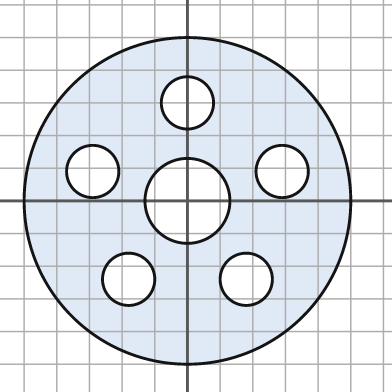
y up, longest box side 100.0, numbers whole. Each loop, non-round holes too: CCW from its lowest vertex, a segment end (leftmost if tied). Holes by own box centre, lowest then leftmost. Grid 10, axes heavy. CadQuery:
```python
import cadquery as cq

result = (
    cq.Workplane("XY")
    .moveTo(0.0, 0.0)
    .circle(50.0)
    .moveTo(-18.0, -24.0)
    .circle(8.0)
    .moveTo(18.0, -24.0)
    .circle(8.0)
    .moveTo(0.0, 0.0)
    .circle(13.0)
    .moveTo(-29.0, 9.0)
    .circle(8.0)
    .moveTo(29.0, 9.0)
    .circle(8.0)
    .moveTo(0.0, 30.0)
    .circle(8.0)
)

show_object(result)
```